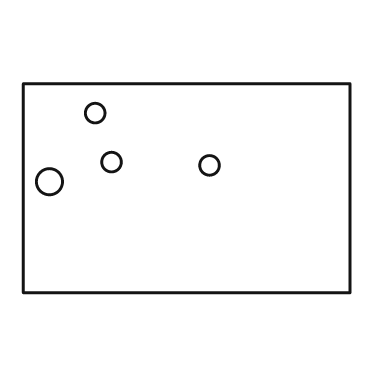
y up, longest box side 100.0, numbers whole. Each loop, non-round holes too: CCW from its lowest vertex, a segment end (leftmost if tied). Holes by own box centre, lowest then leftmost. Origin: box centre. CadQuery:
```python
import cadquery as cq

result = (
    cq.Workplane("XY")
    .moveTo(-50.0, -32.0)
    .lineTo(50.0, -32.0)
    .lineTo(50.0, 32.0)
    .lineTo(-50.0, 32.0)
    .close()
    .moveTo(-42.0, 2.0)
    .circle(4.0)
    .moveTo(7.0, 7.0)
    .circle(3.0)
    .moveTo(-23.0, 8.0)
    .circle(3.0)
    .moveTo(-28.0, 23.0)
    .circle(3.0)
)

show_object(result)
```